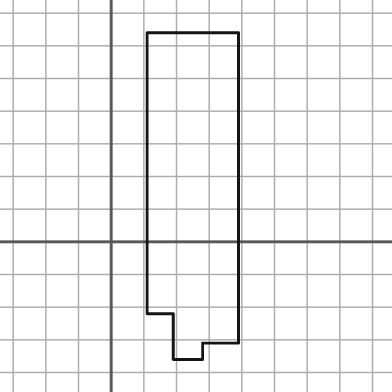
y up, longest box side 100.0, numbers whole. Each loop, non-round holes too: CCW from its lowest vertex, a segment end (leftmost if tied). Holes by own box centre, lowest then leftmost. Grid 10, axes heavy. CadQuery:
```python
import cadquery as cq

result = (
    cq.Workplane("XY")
    .moveTo(19.0, -36.0)
    .lineTo(28.0, -36.0)
    .lineTo(28.0, -31.0)
    .lineTo(39.0, -31.0)
    .lineTo(39.0, 64.0)
    .lineTo(11.0, 64.0)
    .lineTo(11.0, -22.0)
    .lineTo(19.0, -22.0)
    .close()
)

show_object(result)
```